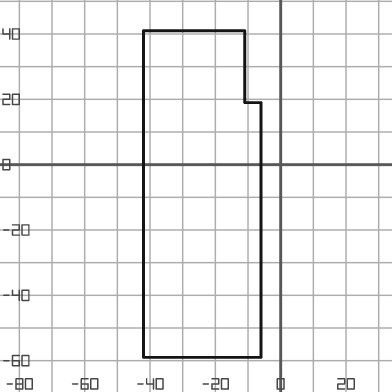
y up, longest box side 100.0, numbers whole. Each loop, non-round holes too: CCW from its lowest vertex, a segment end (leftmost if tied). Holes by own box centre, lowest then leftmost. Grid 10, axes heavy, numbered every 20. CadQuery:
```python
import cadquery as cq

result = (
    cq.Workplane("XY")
    .moveTo(-42.0, -59.0)
    .lineTo(-6.0, -59.0)
    .lineTo(-6.0, 19.0)
    .lineTo(-11.0, 19.0)
    .lineTo(-11.0, 41.0)
    .lineTo(-42.0, 41.0)
    .close()
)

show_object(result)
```